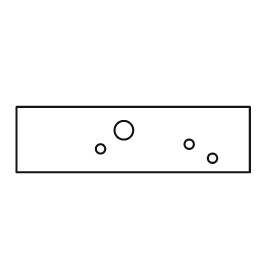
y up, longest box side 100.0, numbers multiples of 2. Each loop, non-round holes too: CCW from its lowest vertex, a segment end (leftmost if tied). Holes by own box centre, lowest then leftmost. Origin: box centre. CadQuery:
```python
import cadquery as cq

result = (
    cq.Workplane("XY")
    .moveTo(-50.0, -14.0)
    .lineTo(50.0, -14.0)
    .lineTo(50.0, 14.0)
    .lineTo(-50.0, 14.0)
    .close()
    .moveTo(34.0, -8.0)
    .circle(2.0)
    .moveTo(-14.0, -4.0)
    .circle(2.0)
    .moveTo(24.0, -2.0)
    .circle(2.0)
    .moveTo(-4.0, 4.0)
    .circle(4.0)
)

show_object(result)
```